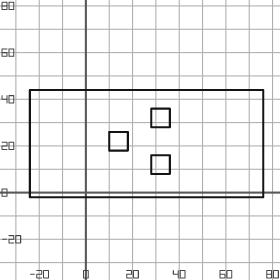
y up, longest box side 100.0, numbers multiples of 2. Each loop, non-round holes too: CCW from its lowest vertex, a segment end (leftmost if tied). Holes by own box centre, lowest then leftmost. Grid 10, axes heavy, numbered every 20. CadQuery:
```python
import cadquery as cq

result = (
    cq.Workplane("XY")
    .moveTo(-24.0, -2.0)
    .lineTo(76.0, -2.0)
    .lineTo(76.0, 44.0)
    .lineTo(-24.0, 44.0)
    .close()
    .moveTo(28.0, 8.0)
    .lineTo(36.0, 8.0)
    .lineTo(36.0, 16.0)
    .lineTo(28.0, 16.0)
    .close()
    .moveTo(10.0, 18.0)
    .lineTo(18.0, 18.0)
    .lineTo(18.0, 26.0)
    .lineTo(10.0, 26.0)
    .close()
    .moveTo(28.0, 28.0)
    .lineTo(36.0, 28.0)
    .lineTo(36.0, 36.0)
    .lineTo(28.0, 36.0)
    .close()
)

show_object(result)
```